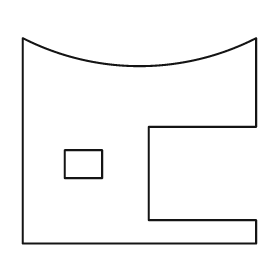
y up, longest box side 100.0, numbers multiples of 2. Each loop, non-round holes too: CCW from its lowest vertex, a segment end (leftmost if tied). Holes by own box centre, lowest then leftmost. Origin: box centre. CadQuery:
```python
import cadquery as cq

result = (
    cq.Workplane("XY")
    .moveTo(-50.0, -44.0)
    .lineTo(50.0, -44.0)
    .lineTo(50.0, -34.0)
    .lineTo(4.0, -34.0)
    .lineTo(4.0, 6.0)
    .lineTo(50.0, 6.0)
    .lineTo(50.0, 44.0)
    .threePointArc((0.0, 32.0), (-50.0, 44.0))
    .close()
    .moveTo(-32.0, -16.0)
    .lineTo(-16.0, -16.0)
    .lineTo(-16.0, -4.0)
    .lineTo(-32.0, -4.0)
    .close()
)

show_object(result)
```